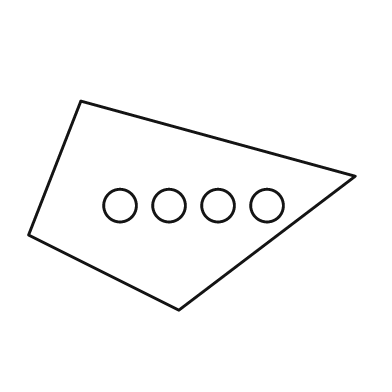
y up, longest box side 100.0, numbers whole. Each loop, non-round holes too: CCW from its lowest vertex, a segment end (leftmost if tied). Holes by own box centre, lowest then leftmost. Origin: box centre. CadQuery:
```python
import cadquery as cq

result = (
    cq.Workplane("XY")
    .moveTo(-4.0, -32.0)
    .lineTo(50.0, 9.0)
    .lineTo(-34.0, 32.0)
    .lineTo(-50.0, -9.0)
    .close()
    .moveTo(-22.0, 0.0)
    .circle(5.0)
    .moveTo(-7.0, 0.0)
    .circle(5.0)
    .moveTo(8.0, 0.0)
    .circle(5.0)
    .moveTo(23.0, 0.0)
    .circle(5.0)
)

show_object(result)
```